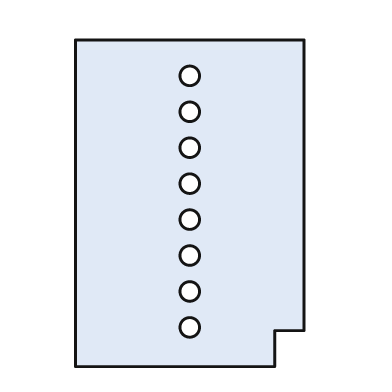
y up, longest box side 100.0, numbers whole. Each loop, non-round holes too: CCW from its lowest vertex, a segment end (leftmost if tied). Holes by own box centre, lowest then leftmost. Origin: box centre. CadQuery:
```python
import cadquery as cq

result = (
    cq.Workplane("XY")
    .moveTo(-35.0, -50.0)
    .lineTo(26.0, -50.0)
    .lineTo(26.0, -39.0)
    .lineTo(35.0, -39.0)
    .lineTo(35.0, 50.0)
    .lineTo(-35.0, 50.0)
    .close()
    .moveTo(0.0, -38.0)
    .circle(3.0)
    .moveTo(0.0, -27.0)
    .circle(3.0)
    .moveTo(0.0, -16.0)
    .circle(3.0)
    .moveTo(0.0, -5.0)
    .circle(3.0)
    .moveTo(0.0, 6.0)
    .circle(3.0)
    .moveTo(0.0, 17.0)
    .circle(3.0)
    .moveTo(0.0, 28.0)
    .circle(3.0)
    .moveTo(0.0, 39.0)
    .circle(3.0)
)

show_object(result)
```